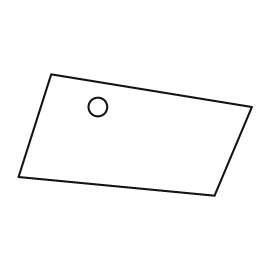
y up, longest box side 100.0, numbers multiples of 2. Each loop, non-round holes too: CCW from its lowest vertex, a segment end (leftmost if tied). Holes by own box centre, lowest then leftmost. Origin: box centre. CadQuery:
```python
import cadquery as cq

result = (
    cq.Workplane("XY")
    .moveTo(34.0, -26.0)
    .lineTo(50.0, 12.0)
    .lineTo(-36.0, 26.0)
    .lineTo(-50.0, -18.0)
    .close()
    .moveTo(-16.0, 12.0)
    .circle(4.0)
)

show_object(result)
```